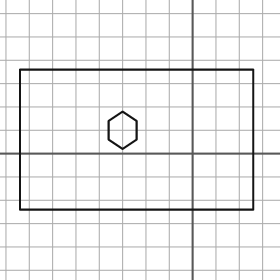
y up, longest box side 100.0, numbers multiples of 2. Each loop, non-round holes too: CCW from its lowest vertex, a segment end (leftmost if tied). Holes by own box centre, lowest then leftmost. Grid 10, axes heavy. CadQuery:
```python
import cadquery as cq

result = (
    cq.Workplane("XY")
    .moveTo(-74.0, -24.0)
    .lineTo(26.0, -24.0)
    .lineTo(26.0, 36.0)
    .lineTo(-74.0, 36.0)
    .close()
    .moveTo(-30.0, 2.0)
    .lineTo(-24.0, 6.0)
    .lineTo(-24.0, 14.0)
    .lineTo(-30.0, 18.0)
    .lineTo(-36.0, 14.0)
    .lineTo(-36.0, 6.0)
    .close()
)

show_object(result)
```